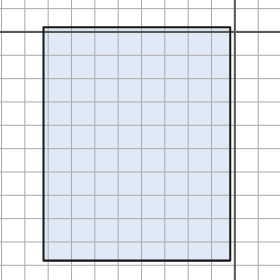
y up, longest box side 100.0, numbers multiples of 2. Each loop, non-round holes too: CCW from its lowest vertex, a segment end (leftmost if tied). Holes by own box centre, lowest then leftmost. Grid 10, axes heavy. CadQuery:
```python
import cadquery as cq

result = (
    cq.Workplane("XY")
    .moveTo(-82.0, -98.0)
    .lineTo(-2.0, -98.0)
    .lineTo(-2.0, 2.0)
    .lineTo(-82.0, 2.0)
    .close()
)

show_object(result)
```